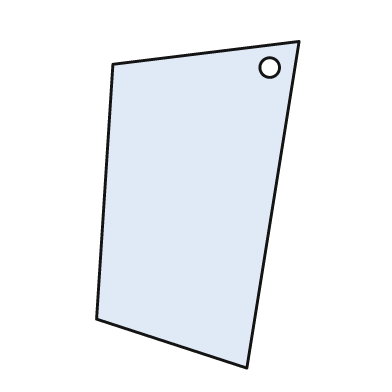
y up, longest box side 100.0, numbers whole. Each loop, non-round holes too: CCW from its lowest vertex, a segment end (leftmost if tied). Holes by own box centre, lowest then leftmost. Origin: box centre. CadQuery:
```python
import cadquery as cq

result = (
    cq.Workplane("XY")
    .moveTo(15.0, -50.0)
    .lineTo(31.0, 50.0)
    .lineTo(-26.0, 43.0)
    .lineTo(-31.0, -35.0)
    .close()
    .moveTo(22.0, 42.0)
    .circle(3.0)
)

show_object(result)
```